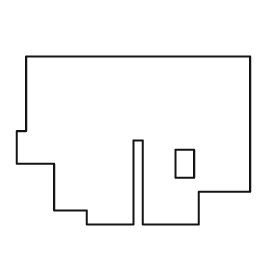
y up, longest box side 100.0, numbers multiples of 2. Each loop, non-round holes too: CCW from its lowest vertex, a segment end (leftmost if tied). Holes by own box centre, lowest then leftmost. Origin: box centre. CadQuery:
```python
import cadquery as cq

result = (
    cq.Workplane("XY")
    .moveTo(-20.0, -36.0)
    .lineTo(0.0, -36.0)
    .lineTo(0.0, 0.0)
    .lineTo(4.0, 0.0)
    .lineTo(4.0, -36.0)
    .lineTo(28.0, -36.0)
    .lineTo(28.0, -22.0)
    .lineTo(50.0, -22.0)
    .lineTo(50.0, 36.0)
    .lineTo(-46.0, 36.0)
    .lineTo(-46.0, 4.0)
    .lineTo(-50.0, 4.0)
    .lineTo(-50.0, -10.0)
    .lineTo(-34.0, -10.0)
    .lineTo(-34.0, -30.0)
    .lineTo(-20.0, -30.0)
    .close()
    .moveTo(18.0, -16.0)
    .lineTo(26.0, -16.0)
    .lineTo(26.0, -4.0)
    .lineTo(18.0, -4.0)
    .close()
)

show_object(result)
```